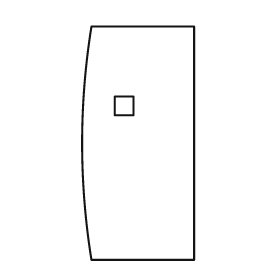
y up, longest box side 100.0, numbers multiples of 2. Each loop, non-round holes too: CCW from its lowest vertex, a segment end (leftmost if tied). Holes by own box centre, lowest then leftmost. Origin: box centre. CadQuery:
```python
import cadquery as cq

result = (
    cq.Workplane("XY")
    .moveTo(-20.0, -50.0)
    .lineTo(24.0, -50.0)
    .lineTo(24.0, 50.0)
    .lineTo(-20.0, 50.0)
    .threePointArc((-24.0, 0.0), (-20.0, -50.0))
    .close()
    .moveTo(-10.0, 12.0)
    .lineTo(-2.0, 12.0)
    .lineTo(-2.0, 20.0)
    .lineTo(-10.0, 20.0)
    .close()
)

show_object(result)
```